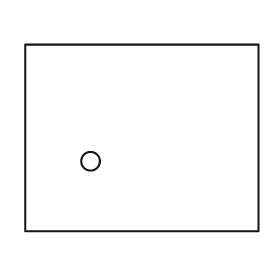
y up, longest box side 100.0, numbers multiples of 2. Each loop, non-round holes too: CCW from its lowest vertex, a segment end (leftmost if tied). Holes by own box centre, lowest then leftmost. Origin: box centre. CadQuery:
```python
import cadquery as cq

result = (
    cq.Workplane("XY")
    .moveTo(-50.0, -40.0)
    .lineTo(50.0, -40.0)
    .lineTo(50.0, 40.0)
    .lineTo(-50.0, 40.0)
    .close()
    .moveTo(-22.0, -10.0)
    .circle(4.0)
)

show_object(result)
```